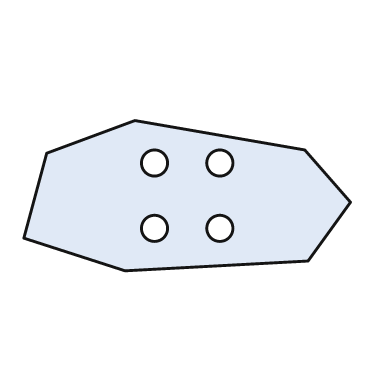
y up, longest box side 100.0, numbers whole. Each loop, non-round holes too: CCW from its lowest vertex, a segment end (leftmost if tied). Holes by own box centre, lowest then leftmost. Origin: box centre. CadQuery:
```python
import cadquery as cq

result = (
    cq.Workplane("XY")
    .moveTo(-19.0, -23.0)
    .lineTo(37.0, -20.0)
    .lineTo(50.0, -2.0)
    .lineTo(36.0, 14.0)
    .lineTo(-16.0, 23.0)
    .lineTo(-43.0, 13.0)
    .lineTo(-50.0, -13.0)
    .close()
    .moveTo(-10.0, -10.0)
    .circle(4.0)
    .moveTo(10.0, -10.0)
    .circle(4.0)
    .moveTo(-10.0, 10.0)
    .circle(4.0)
    .moveTo(10.0, 10.0)
    .circle(4.0)
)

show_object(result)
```